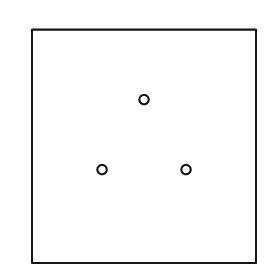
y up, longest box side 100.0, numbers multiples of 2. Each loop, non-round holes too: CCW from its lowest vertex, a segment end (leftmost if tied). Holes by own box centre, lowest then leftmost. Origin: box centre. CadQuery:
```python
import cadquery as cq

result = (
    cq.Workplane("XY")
    .moveTo(-48.0, -50.0)
    .lineTo(48.0, -50.0)
    .lineTo(48.0, 50.0)
    .lineTo(-48.0, 50.0)
    .close()
    .moveTo(-18.0, -10.0)
    .circle(2.0)
    .moveTo(18.0, -10.0)
    .circle(2.0)
    .moveTo(0.0, 20.0)
    .circle(2.0)
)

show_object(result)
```